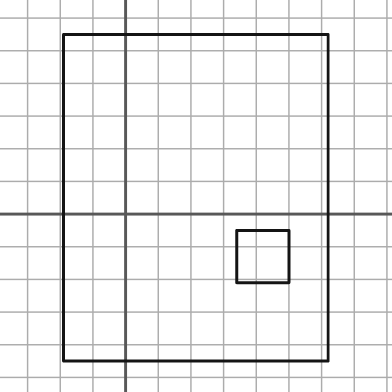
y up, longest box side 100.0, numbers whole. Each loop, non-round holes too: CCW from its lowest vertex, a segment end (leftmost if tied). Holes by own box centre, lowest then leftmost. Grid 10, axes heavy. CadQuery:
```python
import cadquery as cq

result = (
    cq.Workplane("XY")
    .moveTo(-19.0, -45.0)
    .lineTo(62.0, -45.0)
    .lineTo(62.0, 55.0)
    .lineTo(-19.0, 55.0)
    .close()
    .moveTo(34.0, -21.0)
    .lineTo(50.0, -21.0)
    .lineTo(50.0, -5.0)
    .lineTo(34.0, -5.0)
    .close()
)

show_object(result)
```